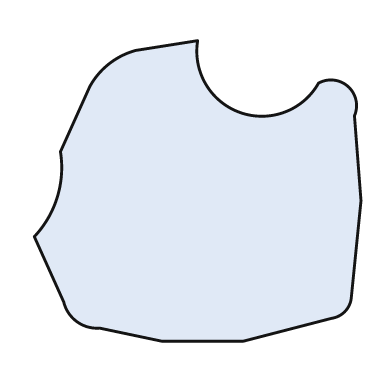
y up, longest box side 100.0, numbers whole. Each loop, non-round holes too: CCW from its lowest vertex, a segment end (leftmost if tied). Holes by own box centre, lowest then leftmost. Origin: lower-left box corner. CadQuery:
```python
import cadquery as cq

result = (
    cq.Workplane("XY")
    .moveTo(39.0, 0.0)
    .lineTo(64.0, 0.0)
    .lineTo(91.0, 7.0)
    .threePointArc((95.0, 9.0), (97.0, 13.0))
    .lineTo(100.0, 43.0)
    .lineTo(98.0, 69.0)
    .threePointArc((96.0, 78.0), (87.0, 79.0))
    .threePointArc((63.0, 70.0), (50.0, 92.0))
    .lineTo(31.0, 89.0)
    .threePointArc((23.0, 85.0), (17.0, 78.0))
    .lineTo(8.0, 58.0)
    .threePointArc((7.0, 44.0), (0.0, 32.0))
    .lineTo(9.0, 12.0)
    .threePointArc((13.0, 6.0), (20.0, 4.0))
    .close()
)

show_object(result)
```